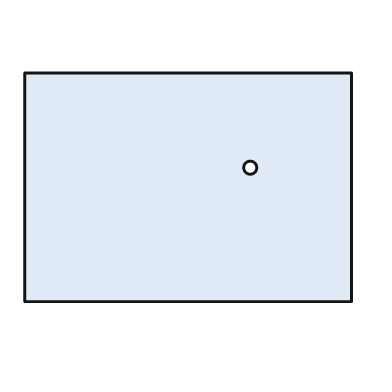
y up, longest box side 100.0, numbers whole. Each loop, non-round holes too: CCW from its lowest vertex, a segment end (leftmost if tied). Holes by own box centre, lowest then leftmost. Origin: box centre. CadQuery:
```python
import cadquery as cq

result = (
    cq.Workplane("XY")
    .moveTo(-50.0, -35.0)
    .lineTo(50.0, -35.0)
    .lineTo(50.0, 35.0)
    .lineTo(-50.0, 35.0)
    .close()
    .moveTo(19.0, 6.0)
    .circle(2.0)
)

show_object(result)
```